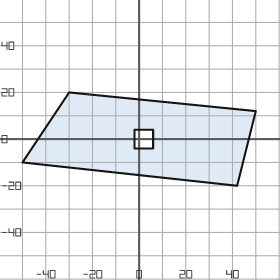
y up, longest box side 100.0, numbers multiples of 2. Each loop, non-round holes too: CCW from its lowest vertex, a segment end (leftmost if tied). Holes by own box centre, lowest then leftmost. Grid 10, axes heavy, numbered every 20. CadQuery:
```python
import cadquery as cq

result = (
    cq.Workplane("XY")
    .moveTo(42.0, -20.0)
    .lineTo(50.0, 12.0)
    .lineTo(-30.0, 20.0)
    .lineTo(-50.0, -10.0)
    .close()
    .moveTo(-2.0, -4.0)
    .lineTo(6.0, -4.0)
    .lineTo(6.0, 4.0)
    .lineTo(-2.0, 4.0)
    .close()
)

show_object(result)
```